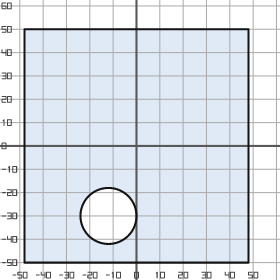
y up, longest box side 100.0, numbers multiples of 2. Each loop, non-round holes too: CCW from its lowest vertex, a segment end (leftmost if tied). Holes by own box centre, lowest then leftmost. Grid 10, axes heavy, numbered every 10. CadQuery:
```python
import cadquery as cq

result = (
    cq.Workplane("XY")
    .moveTo(-48.0, -50.0)
    .lineTo(48.0, -50.0)
    .lineTo(48.0, 50.0)
    .lineTo(-48.0, 50.0)
    .close()
    .moveTo(-12.0, -30.0)
    .circle(12.0)
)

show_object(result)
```